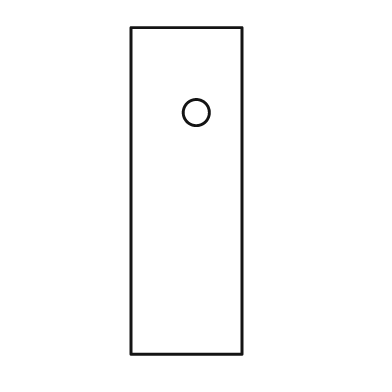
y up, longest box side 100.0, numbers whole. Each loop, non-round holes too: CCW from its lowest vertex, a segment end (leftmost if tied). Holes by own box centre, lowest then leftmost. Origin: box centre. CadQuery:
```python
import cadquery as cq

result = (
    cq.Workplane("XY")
    .moveTo(-17.0, -50.0)
    .lineTo(17.0, -50.0)
    .lineTo(17.0, 50.0)
    .lineTo(-17.0, 50.0)
    .close()
    .moveTo(3.0, 24.0)
    .circle(4.0)
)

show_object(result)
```